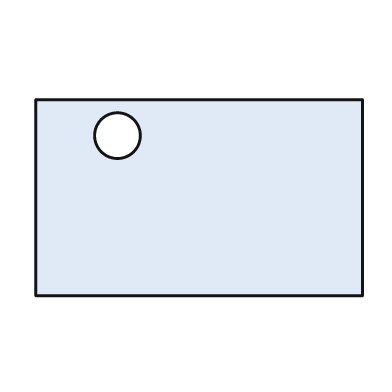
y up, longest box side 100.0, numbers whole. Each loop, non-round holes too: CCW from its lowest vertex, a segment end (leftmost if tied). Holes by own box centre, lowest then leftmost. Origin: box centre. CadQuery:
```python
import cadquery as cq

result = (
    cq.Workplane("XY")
    .moveTo(-50.0, -30.0)
    .lineTo(50.0, -30.0)
    .lineTo(50.0, 30.0)
    .lineTo(-50.0, 30.0)
    .close()
    .moveTo(-25.0, 19.0)
    .circle(7.0)
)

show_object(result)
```